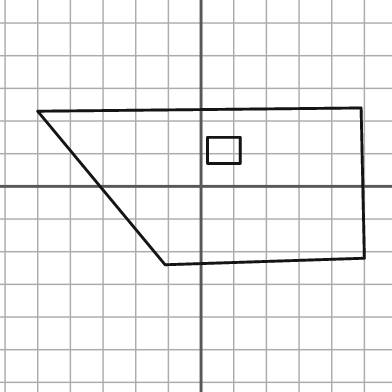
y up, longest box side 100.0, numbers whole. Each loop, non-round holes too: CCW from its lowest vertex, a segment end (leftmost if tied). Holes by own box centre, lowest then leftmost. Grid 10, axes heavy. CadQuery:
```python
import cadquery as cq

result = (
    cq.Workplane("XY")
    .moveTo(-11.0, -24.0)
    .lineTo(50.0, -22.0)
    .lineTo(49.0, 24.0)
    .lineTo(-50.0, 23.0)
    .close()
    .moveTo(2.0, 7.0)
    .lineTo(12.0, 7.0)
    .lineTo(12.0, 15.0)
    .lineTo(2.0, 15.0)
    .close()
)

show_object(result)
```